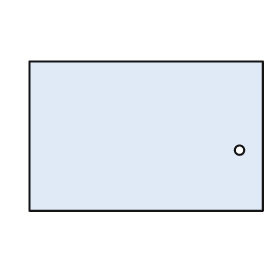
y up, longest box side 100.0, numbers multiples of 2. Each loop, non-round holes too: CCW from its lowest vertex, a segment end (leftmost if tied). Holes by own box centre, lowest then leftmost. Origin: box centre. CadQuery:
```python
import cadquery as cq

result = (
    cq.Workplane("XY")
    .moveTo(-50.0, -32.0)
    .lineTo(50.0, -32.0)
    .lineTo(50.0, 32.0)
    .lineTo(-50.0, 32.0)
    .close()
    .moveTo(40.0, -6.0)
    .circle(2.0)
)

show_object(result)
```